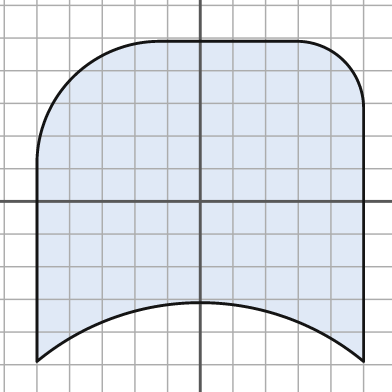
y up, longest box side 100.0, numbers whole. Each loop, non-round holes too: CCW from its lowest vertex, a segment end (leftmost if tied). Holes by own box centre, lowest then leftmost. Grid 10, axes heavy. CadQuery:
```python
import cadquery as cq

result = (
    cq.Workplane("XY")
    .moveTo(-50.0, -49.0)
    .threePointArc((0.0, -31.0), (50.0, -49.0))
    .lineTo(50.0, 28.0)
    .threePointArc((44.0, 43.0), (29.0, 49.0))
    .lineTo(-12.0, 49.0)
    .threePointArc((-39.0, 38.0), (-50.0, 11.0))
    .close()
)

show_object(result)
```